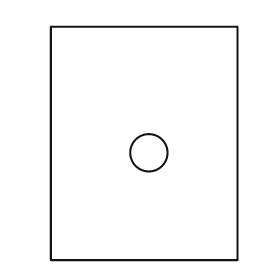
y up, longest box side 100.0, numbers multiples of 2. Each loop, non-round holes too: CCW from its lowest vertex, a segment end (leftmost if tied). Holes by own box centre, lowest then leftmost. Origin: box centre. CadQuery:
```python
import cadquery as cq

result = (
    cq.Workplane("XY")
    .moveTo(-40.0, -50.0)
    .lineTo(40.0, -50.0)
    .lineTo(40.0, 50.0)
    .lineTo(-40.0, 50.0)
    .close()
    .moveTo(2.0, -4.0)
    .circle(8.0)
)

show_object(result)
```